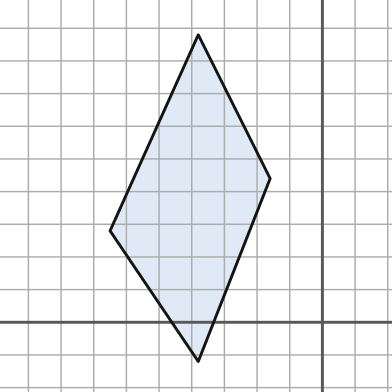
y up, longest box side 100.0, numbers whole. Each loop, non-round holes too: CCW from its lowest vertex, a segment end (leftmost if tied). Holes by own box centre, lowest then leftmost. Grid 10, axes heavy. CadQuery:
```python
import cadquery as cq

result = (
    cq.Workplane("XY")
    .moveTo(-38.0, -12.0)
    .lineTo(-16.0, 44.0)
    .lineTo(-38.0, 88.0)
    .lineTo(-65.0, 28.0)
    .close()
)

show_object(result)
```